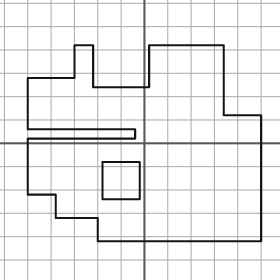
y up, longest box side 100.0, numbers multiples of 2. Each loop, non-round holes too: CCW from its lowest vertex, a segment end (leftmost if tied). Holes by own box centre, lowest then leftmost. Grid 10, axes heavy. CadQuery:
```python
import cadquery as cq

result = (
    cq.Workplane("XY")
    .moveTo(-20.0, -42.0)
    .lineTo(50.0, -42.0)
    .lineTo(50.0, 12.0)
    .lineTo(34.0, 12.0)
    .lineTo(34.0, 42.0)
    .lineTo(2.0, 42.0)
    .lineTo(2.0, 24.0)
    .lineTo(-22.0, 24.0)
    .lineTo(-22.0, 42.0)
    .lineTo(-30.0, 42.0)
    .lineTo(-30.0, 28.0)
    .lineTo(-50.0, 28.0)
    .lineTo(-50.0, 6.0)
    .lineTo(-4.0, 6.0)
    .lineTo(-4.0, 2.0)
    .lineTo(-50.0, 2.0)
    .lineTo(-50.0, -22.0)
    .lineTo(-38.0, -22.0)
    .lineTo(-38.0, -32.0)
    .lineTo(-20.0, -32.0)
    .close()
    .moveTo(-18.0, -24.0)
    .lineTo(-2.0, -24.0)
    .lineTo(-2.0, -8.0)
    .lineTo(-18.0, -8.0)
    .close()
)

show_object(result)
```